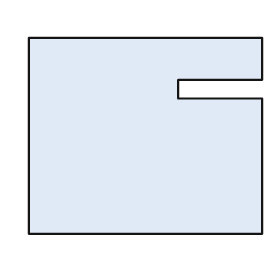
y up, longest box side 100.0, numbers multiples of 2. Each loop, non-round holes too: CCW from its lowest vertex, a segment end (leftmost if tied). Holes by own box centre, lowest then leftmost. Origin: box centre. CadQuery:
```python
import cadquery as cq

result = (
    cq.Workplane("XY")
    .moveTo(-50.0, -42.0)
    .lineTo(50.0, -42.0)
    .lineTo(50.0, 16.0)
    .lineTo(14.0, 16.0)
    .lineTo(14.0, 24.0)
    .lineTo(50.0, 24.0)
    .lineTo(50.0, 42.0)
    .lineTo(-50.0, 42.0)
    .close()
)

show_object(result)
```